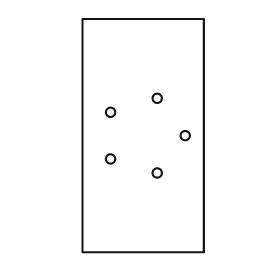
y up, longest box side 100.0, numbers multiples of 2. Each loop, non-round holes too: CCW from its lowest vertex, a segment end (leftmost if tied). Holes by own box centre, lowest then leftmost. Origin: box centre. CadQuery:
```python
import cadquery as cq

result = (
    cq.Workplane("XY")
    .moveTo(-26.0, -50.0)
    .lineTo(26.0, -50.0)
    .lineTo(26.0, 50.0)
    .lineTo(-26.0, 50.0)
    .close()
    .moveTo(6.0, -16.0)
    .circle(2.0)
    .moveTo(-14.0, -10.0)
    .circle(2.0)
    .moveTo(18.0, 0.0)
    .circle(2.0)
    .moveTo(-14.0, 10.0)
    .circle(2.0)
    .moveTo(6.0, 16.0)
    .circle(2.0)
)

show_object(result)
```